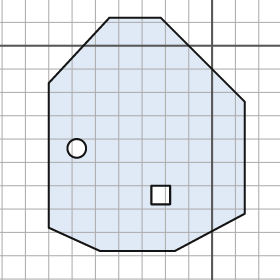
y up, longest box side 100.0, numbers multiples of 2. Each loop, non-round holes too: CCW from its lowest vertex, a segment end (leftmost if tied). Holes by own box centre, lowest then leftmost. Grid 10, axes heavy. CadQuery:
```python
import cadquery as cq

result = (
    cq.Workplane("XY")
    .moveTo(-48.0, -88.0)
    .lineTo(-16.0, -88.0)
    .lineTo(14.0, -72.0)
    .lineTo(14.0, -24.0)
    .lineTo(-22.0, 12.0)
    .lineTo(-44.0, 12.0)
    .lineTo(-70.0, -16.0)
    .lineTo(-70.0, -78.0)
    .close()
    .moveTo(-26.0, -68.0)
    .lineTo(-18.0, -68.0)
    .lineTo(-18.0, -60.0)
    .lineTo(-26.0, -60.0)
    .close()
    .moveTo(-58.0, -44.0)
    .circle(4.0)
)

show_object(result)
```